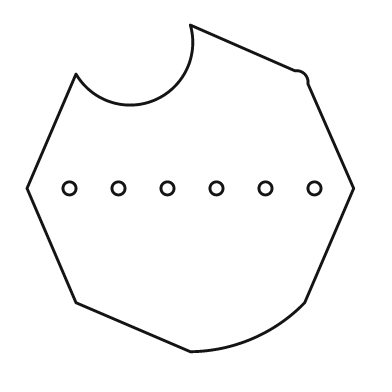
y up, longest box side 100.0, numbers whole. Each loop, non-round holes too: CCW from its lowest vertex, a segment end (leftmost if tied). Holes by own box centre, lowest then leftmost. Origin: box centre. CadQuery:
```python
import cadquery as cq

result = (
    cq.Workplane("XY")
    .moveTo(0.0, -50.0)
    .threePointArc((19.0, -46.0), (35.0, -35.0))
    .lineTo(50.0, 0.0)
    .lineTo(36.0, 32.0)
    .threePointArc((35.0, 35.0), (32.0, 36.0))
    .lineTo(0.0, 50.0)
    .threePointArc((-11.0, 27.0), (-35.0, 35.0))
    .lineTo(-50.0, 0.0)
    .lineTo(-35.0, -35.0)
    .close()
    .moveTo(-37.0, 0.0)
    .circle(2.0)
    .moveTo(-22.0, 0.0)
    .circle(2.0)
    .moveTo(-7.0, 0.0)
    .circle(2.0)
    .moveTo(8.0, 0.0)
    .circle(2.0)
    .moveTo(23.0, 0.0)
    .circle(2.0)
    .moveTo(38.0, 0.0)
    .circle(2.0)
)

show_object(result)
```